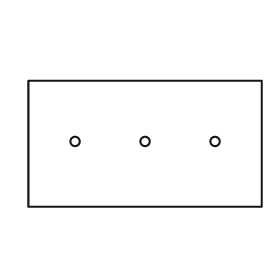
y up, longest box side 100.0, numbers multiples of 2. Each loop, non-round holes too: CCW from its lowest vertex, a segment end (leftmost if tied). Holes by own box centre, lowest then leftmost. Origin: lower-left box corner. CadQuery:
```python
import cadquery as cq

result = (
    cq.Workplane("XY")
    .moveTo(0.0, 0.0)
    .lineTo(100.0, 0.0)
    .lineTo(100.0, 54.0)
    .lineTo(0.0, 54.0)
    .close()
    .moveTo(20.0, 28.0)
    .circle(2.0)
    .moveTo(50.0, 28.0)
    .circle(2.0)
    .moveTo(80.0, 28.0)
    .circle(2.0)
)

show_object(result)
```